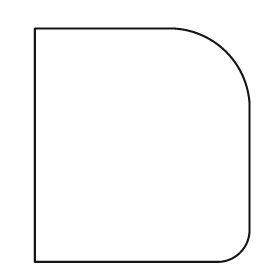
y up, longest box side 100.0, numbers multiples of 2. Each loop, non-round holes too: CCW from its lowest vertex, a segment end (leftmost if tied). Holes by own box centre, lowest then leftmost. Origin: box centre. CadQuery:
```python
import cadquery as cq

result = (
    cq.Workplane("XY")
    .moveTo(-46.0, -50.0)
    .lineTo(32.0, -50.0)
    .threePointArc((42.0, -46.0), (46.0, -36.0))
    .lineTo(46.0, 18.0)
    .threePointArc((36.0, 40.0), (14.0, 50.0))
    .lineTo(-46.0, 50.0)
    .close()
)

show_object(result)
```